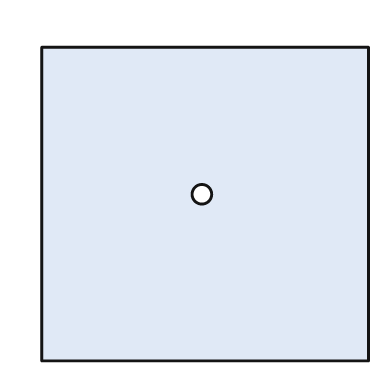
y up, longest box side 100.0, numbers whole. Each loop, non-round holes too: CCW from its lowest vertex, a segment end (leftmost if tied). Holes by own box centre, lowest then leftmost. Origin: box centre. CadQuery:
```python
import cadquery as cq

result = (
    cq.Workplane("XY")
    .moveTo(-50.0, -48.0)
    .lineTo(50.0, -48.0)
    .lineTo(50.0, 48.0)
    .lineTo(-50.0, 48.0)
    .close()
    .moveTo(-1.0, 3.0)
    .circle(3.0)
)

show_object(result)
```